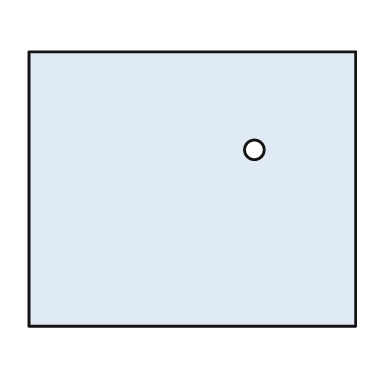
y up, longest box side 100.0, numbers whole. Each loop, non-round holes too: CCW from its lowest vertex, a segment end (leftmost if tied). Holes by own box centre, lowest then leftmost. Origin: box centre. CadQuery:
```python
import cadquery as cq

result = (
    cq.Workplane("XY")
    .moveTo(-50.0, -42.0)
    .lineTo(50.0, -42.0)
    .lineTo(50.0, 42.0)
    .lineTo(-50.0, 42.0)
    .close()
    .moveTo(19.0, 12.0)
    .circle(3.0)
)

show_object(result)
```